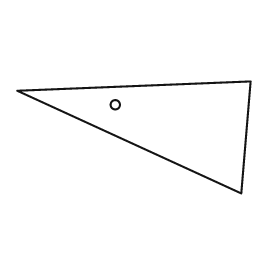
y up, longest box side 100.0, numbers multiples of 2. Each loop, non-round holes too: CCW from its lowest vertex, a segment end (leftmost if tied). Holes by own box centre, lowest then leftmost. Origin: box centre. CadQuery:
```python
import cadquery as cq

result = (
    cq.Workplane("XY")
    .moveTo(46.0, -24.0)
    .lineTo(50.0, 24.0)
    .lineTo(-50.0, 20.0)
    .close()
    .moveTo(-8.0, 14.0)
    .circle(2.0)
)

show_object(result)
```